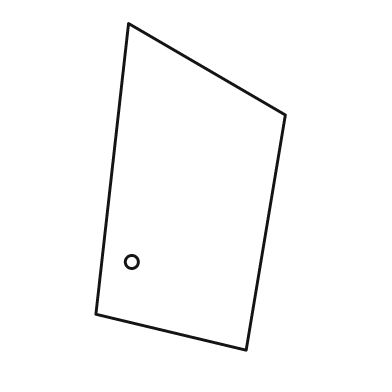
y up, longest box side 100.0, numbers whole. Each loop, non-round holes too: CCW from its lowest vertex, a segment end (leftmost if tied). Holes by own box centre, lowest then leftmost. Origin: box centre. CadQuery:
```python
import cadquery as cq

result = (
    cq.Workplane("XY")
    .moveTo(17.0, -50.0)
    .lineTo(29.0, 22.0)
    .lineTo(-19.0, 50.0)
    .lineTo(-29.0, -39.0)
    .close()
    .moveTo(-18.0, -23.0)
    .circle(2.0)
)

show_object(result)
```